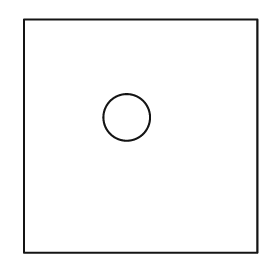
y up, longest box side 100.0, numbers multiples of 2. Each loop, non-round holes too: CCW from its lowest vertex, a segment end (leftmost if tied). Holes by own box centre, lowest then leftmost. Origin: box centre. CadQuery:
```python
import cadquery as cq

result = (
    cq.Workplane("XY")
    .moveTo(-50.0, -50.0)
    .lineTo(50.0, -50.0)
    .lineTo(50.0, 50.0)
    .lineTo(-50.0, 50.0)
    .close()
    .moveTo(-6.0, 8.0)
    .circle(10.0)
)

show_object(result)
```